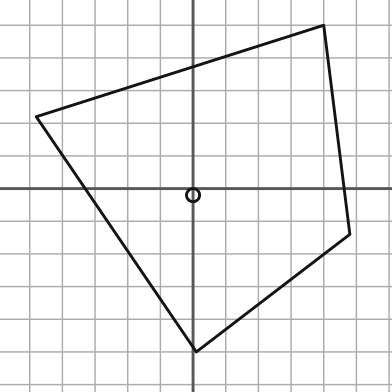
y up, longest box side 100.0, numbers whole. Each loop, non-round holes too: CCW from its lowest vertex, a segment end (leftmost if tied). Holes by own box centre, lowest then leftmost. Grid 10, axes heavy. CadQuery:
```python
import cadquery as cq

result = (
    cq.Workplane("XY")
    .moveTo(1.0, -50.0)
    .lineTo(48.0, -14.0)
    .lineTo(40.0, 50.0)
    .lineTo(-48.0, 22.0)
    .close()
    .moveTo(0.0, -2.0)
    .circle(2.0)
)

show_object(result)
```